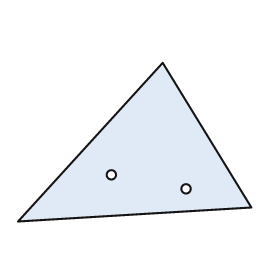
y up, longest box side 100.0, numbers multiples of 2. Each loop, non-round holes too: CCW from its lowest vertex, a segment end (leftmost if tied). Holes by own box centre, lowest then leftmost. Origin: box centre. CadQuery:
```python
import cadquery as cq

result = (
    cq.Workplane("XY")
    .moveTo(-50.0, -34.0)
    .lineTo(50.0, -28.0)
    .lineTo(12.0, 34.0)
    .close()
    .moveTo(22.0, -20.0)
    .circle(2.0)
    .moveTo(-10.0, -14.0)
    .circle(2.0)
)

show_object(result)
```